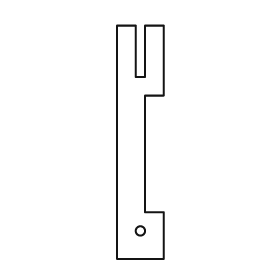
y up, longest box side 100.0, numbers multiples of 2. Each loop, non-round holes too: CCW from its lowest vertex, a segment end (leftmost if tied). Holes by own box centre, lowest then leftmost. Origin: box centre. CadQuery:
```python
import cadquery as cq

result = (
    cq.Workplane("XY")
    .moveTo(-10.0, -50.0)
    .lineTo(10.0, -50.0)
    .lineTo(10.0, -30.0)
    .lineTo(2.0, -30.0)
    .lineTo(2.0, 20.0)
    .lineTo(10.0, 20.0)
    .lineTo(10.0, 50.0)
    .lineTo(2.0, 50.0)
    .lineTo(2.0, 28.0)
    .lineTo(-2.0, 28.0)
    .lineTo(-2.0, 50.0)
    .lineTo(-10.0, 50.0)
    .close()
    .moveTo(0.0, -38.0)
    .circle(2.0)
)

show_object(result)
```